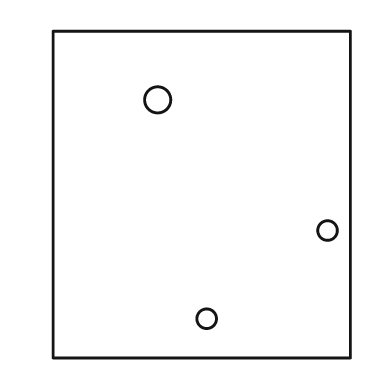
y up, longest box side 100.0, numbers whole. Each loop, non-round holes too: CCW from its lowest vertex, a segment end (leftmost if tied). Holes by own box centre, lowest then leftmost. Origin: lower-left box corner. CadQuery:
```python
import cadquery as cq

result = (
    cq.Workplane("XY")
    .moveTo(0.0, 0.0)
    .lineTo(91.0, 0.0)
    .lineTo(91.0, 100.0)
    .lineTo(0.0, 100.0)
    .close()
    .moveTo(47.0, 12.0)
    .circle(3.0)
    .moveTo(84.0, 39.0)
    .circle(3.0)
    .moveTo(32.0, 79.0)
    .circle(4.0)
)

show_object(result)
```